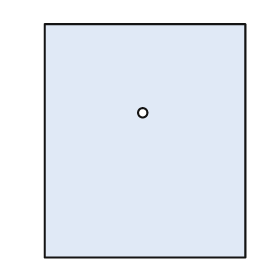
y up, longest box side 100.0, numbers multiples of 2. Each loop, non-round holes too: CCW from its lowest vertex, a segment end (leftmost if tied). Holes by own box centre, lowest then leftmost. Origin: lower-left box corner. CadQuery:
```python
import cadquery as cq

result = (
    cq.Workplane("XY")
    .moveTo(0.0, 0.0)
    .lineTo(86.0, 0.0)
    .lineTo(86.0, 100.0)
    .lineTo(0.0, 100.0)
    .close()
    .moveTo(42.0, 62.0)
    .circle(2.0)
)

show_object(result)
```